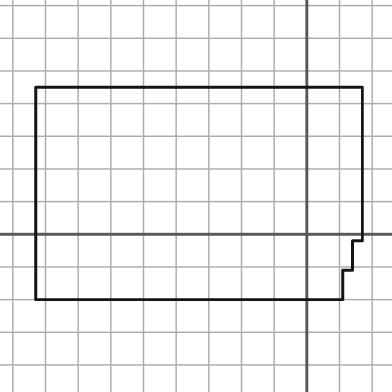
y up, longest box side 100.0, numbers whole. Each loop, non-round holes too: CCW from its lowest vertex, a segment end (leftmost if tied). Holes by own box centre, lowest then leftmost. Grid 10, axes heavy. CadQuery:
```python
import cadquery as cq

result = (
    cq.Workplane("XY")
    .moveTo(-83.0, -20.0)
    .lineTo(11.0, -20.0)
    .lineTo(11.0, -11.0)
    .lineTo(14.0, -11.0)
    .lineTo(14.0, -2.0)
    .lineTo(17.0, -2.0)
    .lineTo(17.0, 45.0)
    .lineTo(-83.0, 45.0)
    .close()
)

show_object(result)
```